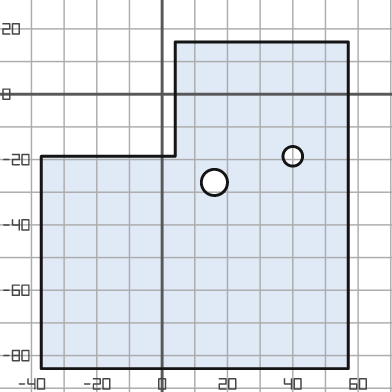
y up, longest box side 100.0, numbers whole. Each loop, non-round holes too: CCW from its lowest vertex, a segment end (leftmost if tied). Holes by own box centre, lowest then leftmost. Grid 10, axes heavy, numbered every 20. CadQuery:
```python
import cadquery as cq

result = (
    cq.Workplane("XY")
    .moveTo(-37.0, -84.0)
    .lineTo(57.0, -84.0)
    .lineTo(57.0, 16.0)
    .lineTo(4.0, 16.0)
    .lineTo(4.0, -19.0)
    .lineTo(-37.0, -19.0)
    .close()
    .moveTo(16.0, -27.0)
    .circle(4.0)
    .moveTo(40.0, -19.0)
    .circle(3.0)
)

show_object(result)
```